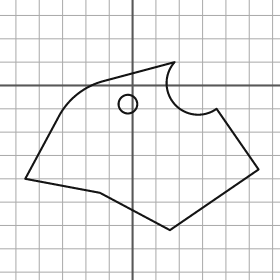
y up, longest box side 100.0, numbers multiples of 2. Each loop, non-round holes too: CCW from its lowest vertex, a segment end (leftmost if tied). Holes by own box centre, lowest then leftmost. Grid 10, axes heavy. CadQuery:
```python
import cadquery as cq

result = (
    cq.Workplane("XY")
    .moveTo(16.0, -62.0)
    .lineTo(54.0, -36.0)
    .lineTo(36.0, -10.0)
    .threePointArc((18.0, -8.0), (18.0, 10.0))
    .lineTo(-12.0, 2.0)
    .threePointArc((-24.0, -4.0), (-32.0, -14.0))
    .lineTo(-46.0, -40.0)
    .lineTo(-14.0, -46.0)
    .close()
    .moveTo(-2.0, -8.0)
    .circle(4.0)
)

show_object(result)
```